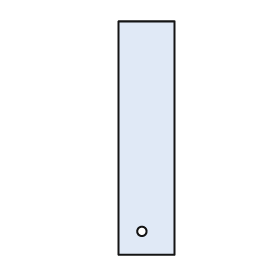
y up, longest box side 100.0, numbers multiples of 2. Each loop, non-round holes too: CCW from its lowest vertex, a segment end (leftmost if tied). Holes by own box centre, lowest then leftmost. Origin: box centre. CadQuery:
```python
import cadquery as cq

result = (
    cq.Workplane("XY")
    .moveTo(-12.0, -50.0)
    .lineTo(12.0, -50.0)
    .lineTo(12.0, 50.0)
    .lineTo(-12.0, 50.0)
    .close()
    .moveTo(-2.0, -40.0)
    .circle(2.0)
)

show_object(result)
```